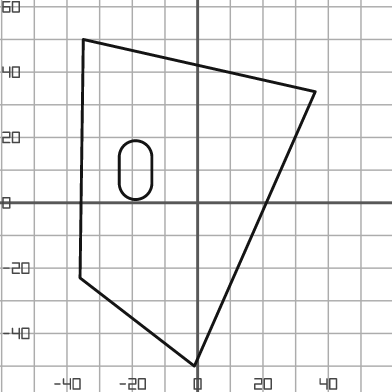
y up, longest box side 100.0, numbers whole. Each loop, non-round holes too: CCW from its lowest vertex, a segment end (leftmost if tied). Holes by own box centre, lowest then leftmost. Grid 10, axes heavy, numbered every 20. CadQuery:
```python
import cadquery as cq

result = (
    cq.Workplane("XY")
    .moveTo(-1.0, -50.0)
    .lineTo(36.0, 34.0)
    .lineTo(-35.0, 50.0)
    .lineTo(-36.0, -23.0)
    .close()
    .moveTo(-24.0, 6.0)
    .threePointArc((-19.0, 1.0), (-14.0, 6.0))
    .lineTo(-14.0, 14.0)
    .threePointArc((-19.0, 19.0), (-24.0, 14.0))
    .close()
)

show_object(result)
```